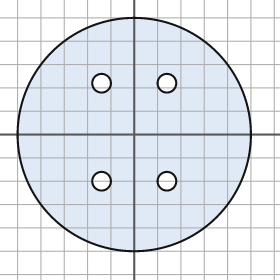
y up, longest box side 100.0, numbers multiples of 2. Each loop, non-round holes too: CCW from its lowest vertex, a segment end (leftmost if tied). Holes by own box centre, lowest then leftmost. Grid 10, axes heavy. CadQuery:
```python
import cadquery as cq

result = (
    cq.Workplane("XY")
    .moveTo(0.0, 0.0)
    .circle(50.0)
    .moveTo(-14.0, -20.0)
    .circle(4.0)
    .moveTo(14.0, -20.0)
    .circle(4.0)
    .moveTo(-14.0, 22.0)
    .circle(4.0)
    .moveTo(14.0, 22.0)
    .circle(4.0)
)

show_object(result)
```